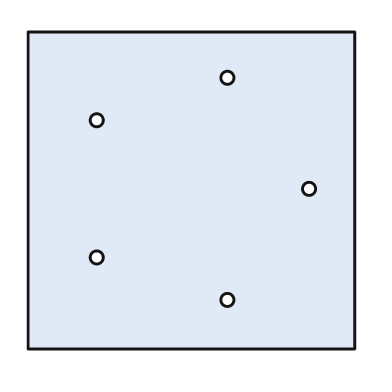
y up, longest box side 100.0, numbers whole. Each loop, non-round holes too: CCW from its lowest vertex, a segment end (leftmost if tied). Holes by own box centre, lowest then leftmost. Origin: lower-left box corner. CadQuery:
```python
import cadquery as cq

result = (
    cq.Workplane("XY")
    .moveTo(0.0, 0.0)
    .lineTo(100.0, 0.0)
    .lineTo(100.0, 97.0)
    .lineTo(0.0, 97.0)
    .close()
    .moveTo(61.0, 15.0)
    .circle(2.0)
    .moveTo(21.0, 28.0)
    .circle(2.0)
    .moveTo(86.0, 49.0)
    .circle(2.0)
    .moveTo(21.0, 70.0)
    .circle(2.0)
    .moveTo(61.0, 83.0)
    .circle(2.0)
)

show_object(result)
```